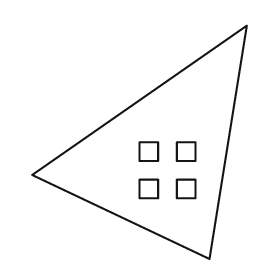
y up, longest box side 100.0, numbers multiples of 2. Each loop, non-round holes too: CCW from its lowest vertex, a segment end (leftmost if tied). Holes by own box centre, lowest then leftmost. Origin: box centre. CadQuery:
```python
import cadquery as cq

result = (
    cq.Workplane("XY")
    .moveTo(30.0, -50.0)
    .lineTo(46.0, 50.0)
    .lineTo(-46.0, -14.0)
    .close()
    .moveTo(0.0, -24.0)
    .lineTo(8.0, -24.0)
    .lineTo(8.0, -16.0)
    .lineTo(0.0, -16.0)
    .close()
    .moveTo(16.0, -24.0)
    .lineTo(24.0, -24.0)
    .lineTo(24.0, -16.0)
    .lineTo(16.0, -16.0)
    .close()
    .moveTo(0.0, -8.0)
    .lineTo(8.0, -8.0)
    .lineTo(8.0, 0.0)
    .lineTo(0.0, 0.0)
    .close()
    .moveTo(16.0, -8.0)
    .lineTo(24.0, -8.0)
    .lineTo(24.0, 0.0)
    .lineTo(16.0, 0.0)
    .close()
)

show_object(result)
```